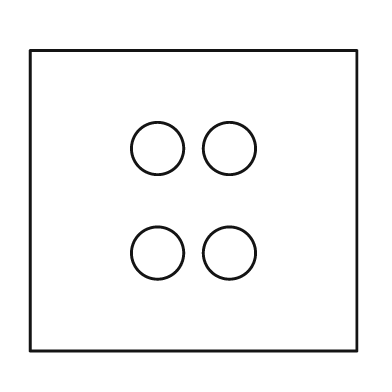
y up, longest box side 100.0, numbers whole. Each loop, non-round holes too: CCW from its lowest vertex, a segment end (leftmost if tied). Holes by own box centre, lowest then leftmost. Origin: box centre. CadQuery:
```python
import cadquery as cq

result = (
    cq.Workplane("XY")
    .moveTo(-50.0, -46.0)
    .lineTo(50.0, -46.0)
    .lineTo(50.0, 46.0)
    .lineTo(-50.0, 46.0)
    .close()
    .moveTo(-11.0, -16.0)
    .circle(8.0)
    .moveTo(11.0, -16.0)
    .circle(8.0)
    .moveTo(-11.0, 16.0)
    .circle(8.0)
    .moveTo(11.0, 16.0)
    .circle(8.0)
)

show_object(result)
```